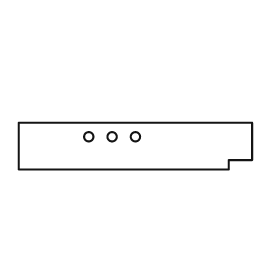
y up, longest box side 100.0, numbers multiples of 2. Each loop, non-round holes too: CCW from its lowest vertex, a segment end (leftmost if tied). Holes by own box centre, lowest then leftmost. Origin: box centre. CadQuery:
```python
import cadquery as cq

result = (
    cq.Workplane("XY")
    .moveTo(-50.0, -10.0)
    .lineTo(40.0, -10.0)
    .lineTo(40.0, -6.0)
    .lineTo(50.0, -6.0)
    .lineTo(50.0, 10.0)
    .lineTo(-50.0, 10.0)
    .close()
    .moveTo(-20.0, 4.0)
    .circle(2.0)
    .moveTo(-10.0, 4.0)
    .circle(2.0)
    .moveTo(0.0, 4.0)
    .circle(2.0)
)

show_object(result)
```